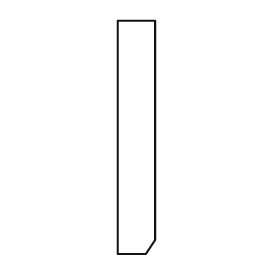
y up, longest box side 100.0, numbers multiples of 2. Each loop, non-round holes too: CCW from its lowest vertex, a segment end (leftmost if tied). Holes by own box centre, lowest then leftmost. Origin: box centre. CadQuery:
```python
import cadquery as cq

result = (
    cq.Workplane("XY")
    .moveTo(-8.0, -50.0)
    .lineTo(4.0, -50.0)
    .lineTo(8.0, -44.0)
    .lineTo(8.0, 50.0)
    .lineTo(-8.0, 50.0)
    .close()
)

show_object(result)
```